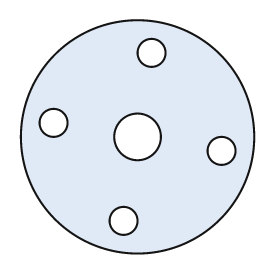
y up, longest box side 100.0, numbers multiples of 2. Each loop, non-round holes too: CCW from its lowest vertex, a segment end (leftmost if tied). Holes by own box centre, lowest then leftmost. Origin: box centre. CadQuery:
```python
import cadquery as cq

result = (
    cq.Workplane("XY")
    .moveTo(0.0, 0.0)
    .circle(50.0)
    .moveTo(-6.0, -36.0)
    .circle(6.0)
    .moveTo(36.0, -6.0)
    .circle(6.0)
    .moveTo(0.0, 0.0)
    .circle(10.0)
    .moveTo(-36.0, 6.0)
    .circle(6.0)
    .moveTo(6.0, 36.0)
    .circle(6.0)
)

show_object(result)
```